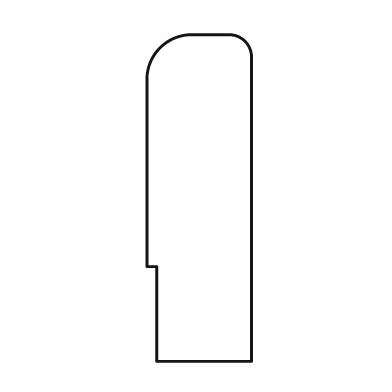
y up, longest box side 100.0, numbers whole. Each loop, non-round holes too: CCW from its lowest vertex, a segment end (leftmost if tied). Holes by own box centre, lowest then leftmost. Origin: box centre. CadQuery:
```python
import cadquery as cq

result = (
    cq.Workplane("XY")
    .moveTo(-13.0, -50.0)
    .lineTo(16.0, -50.0)
    .lineTo(16.0, 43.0)
    .threePointArc((14.0, 48.0), (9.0, 50.0))
    .lineTo(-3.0, 50.0)
    .threePointArc((-12.0, 46.0), (-16.0, 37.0))
    .lineTo(-16.0, -21.0)
    .lineTo(-13.0, -21.0)
    .close()
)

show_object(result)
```